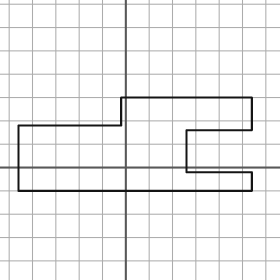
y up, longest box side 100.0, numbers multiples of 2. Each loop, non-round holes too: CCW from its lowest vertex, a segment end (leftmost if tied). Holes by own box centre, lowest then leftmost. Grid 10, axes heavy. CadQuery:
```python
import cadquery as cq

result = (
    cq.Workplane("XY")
    .moveTo(-46.0, -10.0)
    .lineTo(54.0, -10.0)
    .lineTo(54.0, -2.0)
    .lineTo(26.0, -2.0)
    .lineTo(26.0, 16.0)
    .lineTo(54.0, 16.0)
    .lineTo(54.0, 30.0)
    .lineTo(-2.0, 30.0)
    .lineTo(-2.0, 18.0)
    .lineTo(-46.0, 18.0)
    .close()
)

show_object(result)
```